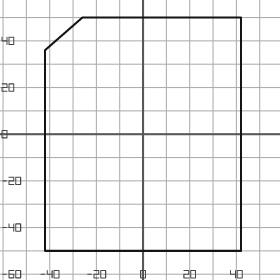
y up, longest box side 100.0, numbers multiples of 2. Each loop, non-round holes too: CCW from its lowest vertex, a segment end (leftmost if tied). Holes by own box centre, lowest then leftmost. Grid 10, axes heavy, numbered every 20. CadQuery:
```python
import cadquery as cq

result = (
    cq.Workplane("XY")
    .moveTo(-42.0, -50.0)
    .lineTo(42.0, -50.0)
    .lineTo(42.0, 50.0)
    .lineTo(-26.0, 50.0)
    .lineTo(-42.0, 36.0)
    .close()
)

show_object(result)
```